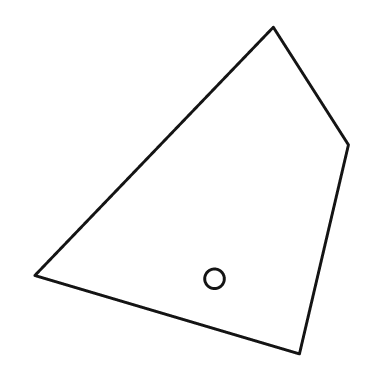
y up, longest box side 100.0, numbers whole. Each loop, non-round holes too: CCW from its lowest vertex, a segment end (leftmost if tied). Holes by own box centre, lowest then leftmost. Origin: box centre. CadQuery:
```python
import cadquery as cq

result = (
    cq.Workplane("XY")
    .moveTo(33.0, -50.0)
    .lineTo(48.0, 14.0)
    .lineTo(25.0, 50.0)
    .lineTo(-48.0, -26.0)
    .close()
    .moveTo(7.0, -27.0)
    .circle(3.0)
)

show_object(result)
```